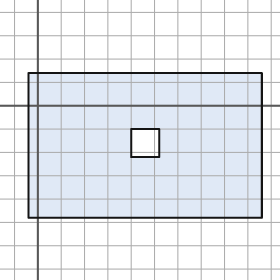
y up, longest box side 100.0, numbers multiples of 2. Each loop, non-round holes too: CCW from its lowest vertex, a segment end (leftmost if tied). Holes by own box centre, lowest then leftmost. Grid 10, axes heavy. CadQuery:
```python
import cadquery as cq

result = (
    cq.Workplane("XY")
    .moveTo(-4.0, -48.0)
    .lineTo(96.0, -48.0)
    .lineTo(96.0, 14.0)
    .lineTo(-4.0, 14.0)
    .close()
    .moveTo(40.0, -22.0)
    .lineTo(52.0, -22.0)
    .lineTo(52.0, -10.0)
    .lineTo(40.0, -10.0)
    .close()
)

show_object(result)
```